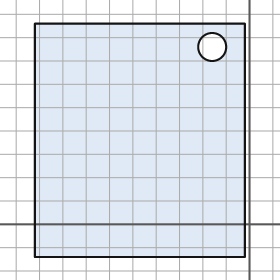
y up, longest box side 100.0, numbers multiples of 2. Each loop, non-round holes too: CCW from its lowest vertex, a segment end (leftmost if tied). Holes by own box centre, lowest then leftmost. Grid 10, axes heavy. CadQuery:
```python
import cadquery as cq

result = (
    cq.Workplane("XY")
    .moveTo(-92.0, -14.0)
    .lineTo(-2.0, -14.0)
    .lineTo(-2.0, 86.0)
    .lineTo(-92.0, 86.0)
    .close()
    .moveTo(-16.0, 76.0)
    .circle(6.0)
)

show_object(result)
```